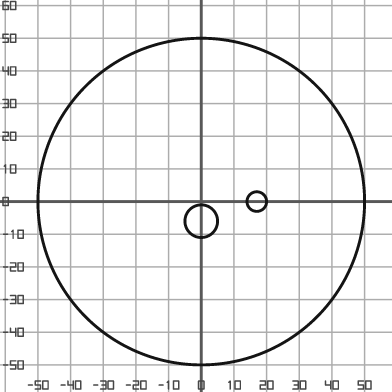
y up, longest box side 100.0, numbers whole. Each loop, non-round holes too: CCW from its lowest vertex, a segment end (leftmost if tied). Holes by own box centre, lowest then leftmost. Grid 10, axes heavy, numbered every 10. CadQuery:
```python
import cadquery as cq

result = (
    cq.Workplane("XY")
    .moveTo(0.0, 0.0)
    .circle(50.0)
    .moveTo(0.0, -6.0)
    .circle(5.0)
    .moveTo(17.0, 0.0)
    .circle(3.0)
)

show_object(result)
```